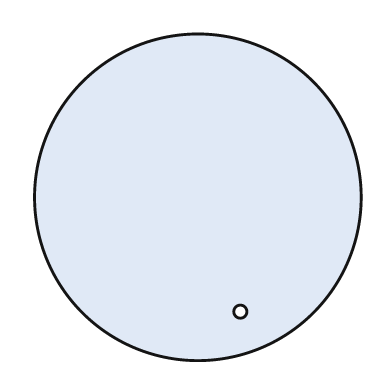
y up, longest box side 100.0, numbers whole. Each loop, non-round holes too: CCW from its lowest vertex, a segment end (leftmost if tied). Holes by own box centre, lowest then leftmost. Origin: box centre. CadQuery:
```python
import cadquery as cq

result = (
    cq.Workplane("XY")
    .moveTo(0.0, 0.0)
    .circle(50.0)
    .moveTo(13.0, -35.0)
    .circle(2.0)
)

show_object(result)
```